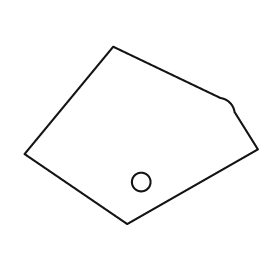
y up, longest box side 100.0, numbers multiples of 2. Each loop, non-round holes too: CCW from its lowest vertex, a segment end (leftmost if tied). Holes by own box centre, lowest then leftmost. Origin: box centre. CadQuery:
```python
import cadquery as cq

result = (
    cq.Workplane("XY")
    .moveTo(-6.0, -38.0)
    .lineTo(50.0, -6.0)
    .lineTo(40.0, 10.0)
    .threePointArc((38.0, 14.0), (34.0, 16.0))
    .lineTo(-12.0, 38.0)
    .lineTo(-50.0, -8.0)
    .close()
    .moveTo(0.0, -20.0)
    .circle(4.0)
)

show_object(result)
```